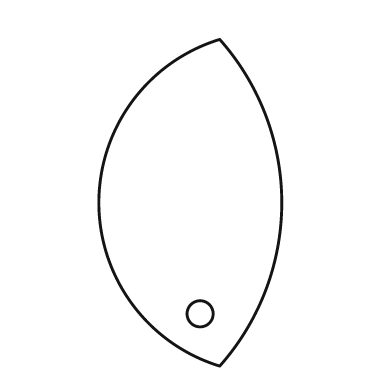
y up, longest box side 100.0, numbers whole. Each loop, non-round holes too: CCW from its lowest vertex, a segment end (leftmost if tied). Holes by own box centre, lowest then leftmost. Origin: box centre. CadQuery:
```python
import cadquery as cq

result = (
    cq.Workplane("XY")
    .moveTo(9.0, -50.0)
    .threePointArc((28.0, 0.0), (9.0, 50.0))
    .threePointArc((-28.0, 0.0), (9.0, -50.0))
    .close()
    .moveTo(3.0, -34.0)
    .circle(4.0)
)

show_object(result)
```